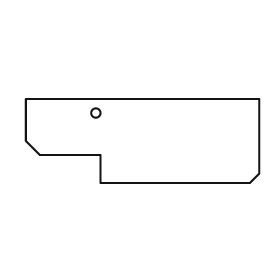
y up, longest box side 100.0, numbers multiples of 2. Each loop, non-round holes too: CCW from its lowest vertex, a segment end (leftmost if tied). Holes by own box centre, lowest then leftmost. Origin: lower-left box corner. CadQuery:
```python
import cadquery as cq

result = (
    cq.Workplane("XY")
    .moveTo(32.0, 0.0)
    .lineTo(96.0, 0.0)
    .lineTo(100.0, 4.0)
    .lineTo(100.0, 36.0)
    .lineTo(0.0, 36.0)
    .lineTo(0.0, 18.0)
    .lineTo(6.0, 12.0)
    .lineTo(32.0, 12.0)
    .close()
    .moveTo(30.0, 30.0)
    .circle(2.0)
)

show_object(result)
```